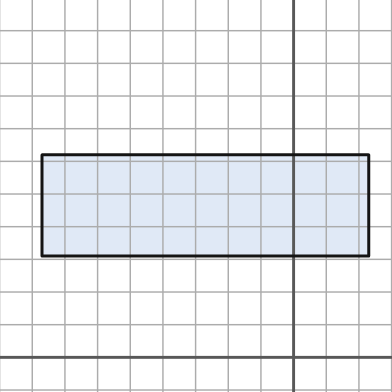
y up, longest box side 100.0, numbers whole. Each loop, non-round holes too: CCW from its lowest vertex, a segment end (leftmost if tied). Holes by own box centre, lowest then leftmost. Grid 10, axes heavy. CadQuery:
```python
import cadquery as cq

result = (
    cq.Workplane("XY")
    .moveTo(-77.0, 31.0)
    .lineTo(23.0, 31.0)
    .lineTo(23.0, 62.0)
    .lineTo(-77.0, 62.0)
    .close()
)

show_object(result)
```